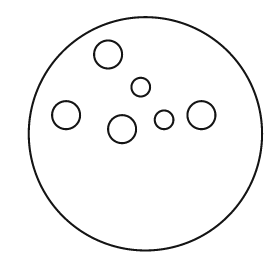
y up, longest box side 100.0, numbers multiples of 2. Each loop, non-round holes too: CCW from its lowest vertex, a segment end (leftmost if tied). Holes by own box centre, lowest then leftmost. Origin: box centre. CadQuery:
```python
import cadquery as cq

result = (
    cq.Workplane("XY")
    .moveTo(0.0, 0.0)
    .circle(50.0)
    .moveTo(-10.0, 2.0)
    .circle(6.0)
    .moveTo(8.0, 6.0)
    .circle(4.0)
    .moveTo(-34.0, 8.0)
    .circle(6.0)
    .moveTo(24.0, 8.0)
    .circle(6.0)
    .moveTo(-2.0, 20.0)
    .circle(4.0)
    .moveTo(-16.0, 34.0)
    .circle(6.0)
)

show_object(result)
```